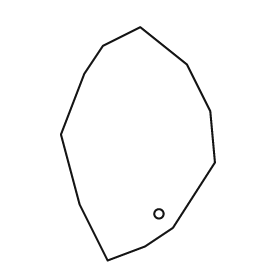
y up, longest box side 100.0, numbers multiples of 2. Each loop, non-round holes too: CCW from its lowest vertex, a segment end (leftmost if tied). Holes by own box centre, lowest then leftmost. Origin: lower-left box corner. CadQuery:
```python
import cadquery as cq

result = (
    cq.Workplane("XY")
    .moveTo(20.0, 0.0)
    .lineTo(36.0, 6.0)
    .lineTo(48.0, 14.0)
    .lineTo(66.0, 42.0)
    .lineTo(64.0, 64.0)
    .lineTo(54.0, 84.0)
    .lineTo(34.0, 100.0)
    .lineTo(18.0, 92.0)
    .lineTo(10.0, 80.0)
    .lineTo(0.0, 54.0)
    .lineTo(8.0, 24.0)
    .close()
    .moveTo(42.0, 20.0)
    .circle(2.0)
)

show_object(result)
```